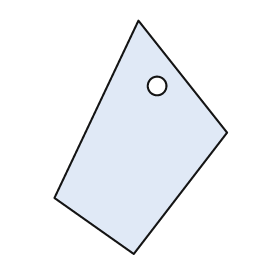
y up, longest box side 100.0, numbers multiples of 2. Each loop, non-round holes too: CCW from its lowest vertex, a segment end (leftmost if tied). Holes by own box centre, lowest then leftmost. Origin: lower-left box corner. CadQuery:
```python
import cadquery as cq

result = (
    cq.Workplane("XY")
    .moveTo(34.0, 0.0)
    .lineTo(74.0, 52.0)
    .lineTo(36.0, 100.0)
    .lineTo(0.0, 24.0)
    .close()
    .moveTo(44.0, 72.0)
    .circle(4.0)
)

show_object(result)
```